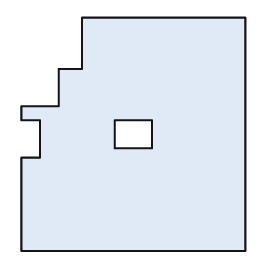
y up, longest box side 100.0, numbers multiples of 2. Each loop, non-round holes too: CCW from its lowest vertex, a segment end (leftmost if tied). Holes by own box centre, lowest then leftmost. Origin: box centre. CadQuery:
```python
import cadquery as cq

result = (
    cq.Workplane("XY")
    .moveTo(-48.0, -50.0)
    .lineTo(48.0, -50.0)
    .lineTo(48.0, 50.0)
    .lineTo(-22.0, 50.0)
    .lineTo(-22.0, 28.0)
    .lineTo(-32.0, 28.0)
    .lineTo(-32.0, 12.0)
    .lineTo(-48.0, 12.0)
    .lineTo(-48.0, 6.0)
    .lineTo(-40.0, 6.0)
    .lineTo(-40.0, -10.0)
    .lineTo(-48.0, -10.0)
    .close()
    .moveTo(-8.0, -6.0)
    .lineTo(8.0, -6.0)
    .lineTo(8.0, 6.0)
    .lineTo(-8.0, 6.0)
    .close()
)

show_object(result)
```